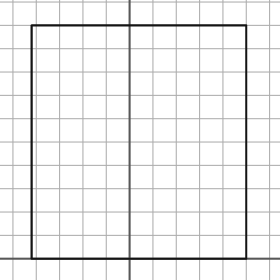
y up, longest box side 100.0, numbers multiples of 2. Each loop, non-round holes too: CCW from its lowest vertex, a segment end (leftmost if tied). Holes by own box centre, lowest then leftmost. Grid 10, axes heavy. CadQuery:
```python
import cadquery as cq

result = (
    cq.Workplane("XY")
    .moveTo(-42.0, 0.0)
    .lineTo(50.0, 0.0)
    .lineTo(50.0, 100.0)
    .lineTo(-42.0, 100.0)
    .close()
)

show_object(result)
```